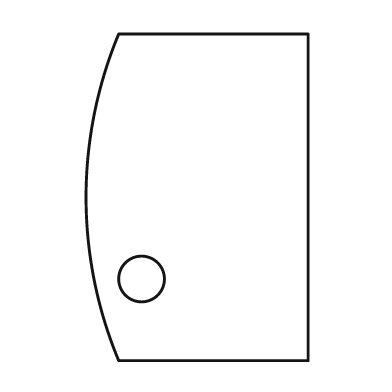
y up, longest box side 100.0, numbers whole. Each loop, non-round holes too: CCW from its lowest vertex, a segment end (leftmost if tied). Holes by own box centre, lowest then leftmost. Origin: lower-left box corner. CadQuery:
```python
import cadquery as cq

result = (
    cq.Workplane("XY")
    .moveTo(10.0, 0.0)
    .lineTo(68.0, 0.0)
    .lineTo(68.0, 100.0)
    .lineTo(10.0, 100.0)
    .threePointArc((0.0, 50.0), (10.0, 0.0))
    .close()
    .moveTo(17.0, 25.0)
    .circle(7.0)
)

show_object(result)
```